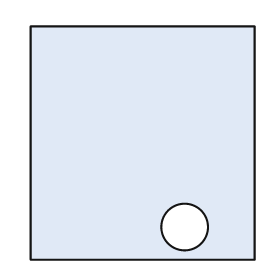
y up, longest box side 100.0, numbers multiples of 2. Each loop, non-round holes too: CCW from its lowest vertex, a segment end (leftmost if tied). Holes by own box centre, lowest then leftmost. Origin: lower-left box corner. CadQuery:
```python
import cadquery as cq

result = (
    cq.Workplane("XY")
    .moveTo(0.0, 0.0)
    .lineTo(96.0, 0.0)
    .lineTo(96.0, 100.0)
    .lineTo(0.0, 100.0)
    .close()
    .moveTo(66.0, 14.0)
    .circle(10.0)
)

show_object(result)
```